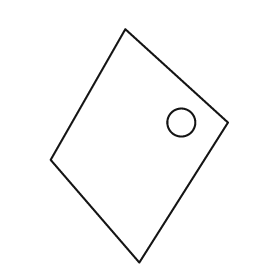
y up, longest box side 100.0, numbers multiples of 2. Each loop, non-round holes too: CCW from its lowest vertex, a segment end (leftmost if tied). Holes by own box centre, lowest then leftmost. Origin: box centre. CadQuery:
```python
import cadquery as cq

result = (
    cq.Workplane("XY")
    .moveTo(0.0, -50.0)
    .lineTo(38.0, 10.0)
    .lineTo(-6.0, 50.0)
    .lineTo(-38.0, -6.0)
    .close()
    .moveTo(18.0, 10.0)
    .circle(6.0)
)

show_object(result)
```